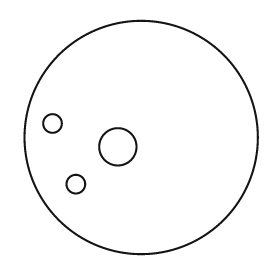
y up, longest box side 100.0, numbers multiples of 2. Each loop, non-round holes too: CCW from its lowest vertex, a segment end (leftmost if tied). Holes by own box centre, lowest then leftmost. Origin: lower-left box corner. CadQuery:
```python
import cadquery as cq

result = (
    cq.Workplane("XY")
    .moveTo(50.0, 50.0)
    .circle(50.0)
    .moveTo(22.0, 30.0)
    .circle(4.0)
    .moveTo(40.0, 46.0)
    .circle(8.0)
    .moveTo(12.0, 56.0)
    .circle(4.0)
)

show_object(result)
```